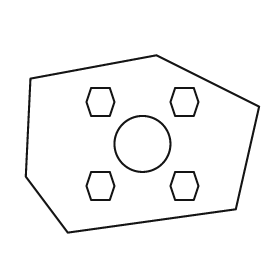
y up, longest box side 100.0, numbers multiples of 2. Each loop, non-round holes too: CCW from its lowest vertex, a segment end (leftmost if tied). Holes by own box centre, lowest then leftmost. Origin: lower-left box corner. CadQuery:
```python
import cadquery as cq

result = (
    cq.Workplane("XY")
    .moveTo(18.0, 0.0)
    .lineTo(90.0, 10.0)
    .lineTo(100.0, 54.0)
    .lineTo(56.0, 76.0)
    .lineTo(2.0, 66.0)
    .lineTo(0.0, 24.0)
    .close()
    .moveTo(28.0, 14.0)
    .lineTo(36.0, 14.0)
    .lineTo(38.0, 20.0)
    .lineTo(36.0, 26.0)
    .lineTo(28.0, 26.0)
    .lineTo(26.0, 20.0)
    .close()
    .moveTo(64.0, 14.0)
    .lineTo(72.0, 14.0)
    .lineTo(74.0, 20.0)
    .lineTo(72.0, 26.0)
    .lineTo(64.0, 26.0)
    .lineTo(62.0, 20.0)
    .close()
    .moveTo(50.0, 38.0)
    .circle(12.0)
    .moveTo(28.0, 50.0)
    .lineTo(36.0, 50.0)
    .lineTo(38.0, 56.0)
    .lineTo(36.0, 62.0)
    .lineTo(28.0, 62.0)
    .lineTo(26.0, 56.0)
    .close()
    .moveTo(64.0, 50.0)
    .lineTo(72.0, 50.0)
    .lineTo(74.0, 56.0)
    .lineTo(72.0, 62.0)
    .lineTo(64.0, 62.0)
    .lineTo(62.0, 56.0)
    .close()
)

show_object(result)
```